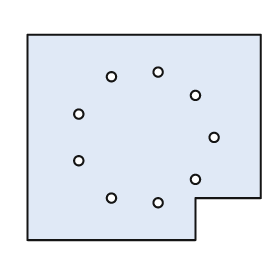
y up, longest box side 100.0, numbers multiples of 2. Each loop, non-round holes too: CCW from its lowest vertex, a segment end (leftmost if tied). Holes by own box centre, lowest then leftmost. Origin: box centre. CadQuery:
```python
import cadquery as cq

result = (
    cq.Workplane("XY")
    .moveTo(-50.0, -44.0)
    .lineTo(22.0, -44.0)
    .lineTo(22.0, -26.0)
    .lineTo(50.0, -26.0)
    .lineTo(50.0, 44.0)
    .lineTo(-50.0, 44.0)
    .close()
    .moveTo(6.0, -28.0)
    .circle(2.0)
    .moveTo(-14.0, -26.0)
    .circle(2.0)
    .moveTo(22.0, -18.0)
    .circle(2.0)
    .moveTo(-28.0, -10.0)
    .circle(2.0)
    .moveTo(30.0, 0.0)
    .circle(2.0)
    .moveTo(-28.0, 10.0)
    .circle(2.0)
    .moveTo(22.0, 18.0)
    .circle(2.0)
    .moveTo(-14.0, 26.0)
    .circle(2.0)
    .moveTo(6.0, 28.0)
    .circle(2.0)
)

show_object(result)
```